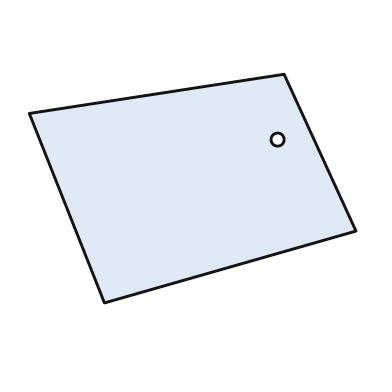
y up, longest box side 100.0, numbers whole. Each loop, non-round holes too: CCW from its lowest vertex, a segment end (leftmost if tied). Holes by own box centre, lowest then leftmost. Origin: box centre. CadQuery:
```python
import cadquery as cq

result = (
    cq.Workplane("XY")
    .moveTo(-27.0, -35.0)
    .lineTo(50.0, -13.0)
    .lineTo(28.0, 35.0)
    .lineTo(-50.0, 23.0)
    .close()
    .moveTo(26.0, 15.0)
    .circle(2.0)
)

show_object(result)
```